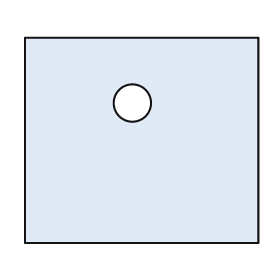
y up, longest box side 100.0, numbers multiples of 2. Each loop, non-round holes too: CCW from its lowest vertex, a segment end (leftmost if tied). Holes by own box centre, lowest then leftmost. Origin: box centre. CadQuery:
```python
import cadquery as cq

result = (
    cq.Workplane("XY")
    .moveTo(-50.0, -44.0)
    .lineTo(50.0, -44.0)
    .lineTo(50.0, 44.0)
    .lineTo(-50.0, 44.0)
    .close()
    .moveTo(-4.0, 16.0)
    .circle(8.0)
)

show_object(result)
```